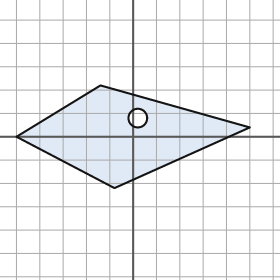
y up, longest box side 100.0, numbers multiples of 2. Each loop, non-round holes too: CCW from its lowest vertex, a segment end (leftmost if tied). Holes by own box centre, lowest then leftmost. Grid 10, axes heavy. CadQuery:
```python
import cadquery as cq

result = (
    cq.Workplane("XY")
    .moveTo(-8.0, -22.0)
    .lineTo(50.0, 4.0)
    .lineTo(-14.0, 22.0)
    .lineTo(-50.0, 0.0)
    .close()
    .moveTo(2.0, 8.0)
    .circle(4.0)
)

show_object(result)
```